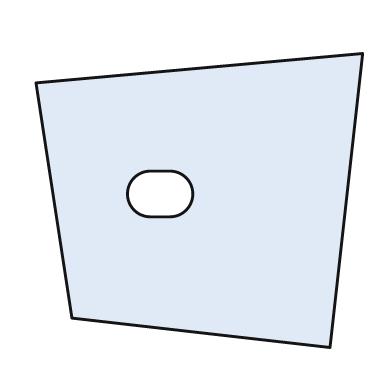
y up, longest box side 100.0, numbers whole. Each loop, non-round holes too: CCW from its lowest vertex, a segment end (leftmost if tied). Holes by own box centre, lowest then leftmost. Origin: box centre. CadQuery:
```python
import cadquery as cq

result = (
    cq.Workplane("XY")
    .moveTo(40.0, -45.0)
    .lineTo(50.0, 45.0)
    .lineTo(-50.0, 36.0)
    .lineTo(-39.0, -36.0)
    .close()
    .moveTo(-15.0, -5.0)
    .lineTo(-9.0, -5.0)
    .threePointArc((-2.0, 2.0), (-9.0, 9.0))
    .lineTo(-15.0, 9.0)
    .threePointArc((-22.0, 2.0), (-15.0, -5.0))
    .close()
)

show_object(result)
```